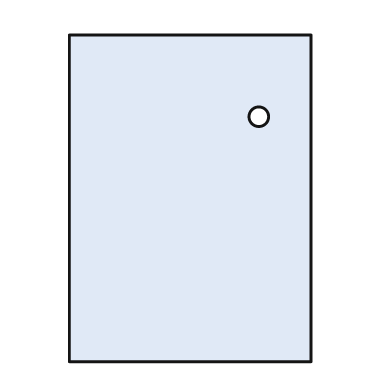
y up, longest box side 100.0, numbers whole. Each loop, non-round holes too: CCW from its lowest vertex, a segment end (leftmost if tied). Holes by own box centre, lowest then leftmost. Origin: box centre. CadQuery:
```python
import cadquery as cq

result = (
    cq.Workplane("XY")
    .moveTo(-37.0, -50.0)
    .lineTo(37.0, -50.0)
    .lineTo(37.0, 50.0)
    .lineTo(-37.0, 50.0)
    .close()
    .moveTo(21.0, 25.0)
    .circle(3.0)
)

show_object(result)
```